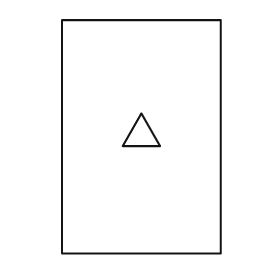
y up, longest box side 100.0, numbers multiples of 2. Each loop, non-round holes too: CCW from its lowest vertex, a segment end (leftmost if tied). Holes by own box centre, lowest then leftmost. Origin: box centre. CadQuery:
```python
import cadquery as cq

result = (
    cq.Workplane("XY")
    .moveTo(-34.0, -50.0)
    .lineTo(34.0, -50.0)
    .lineTo(34.0, 50.0)
    .lineTo(-34.0, 50.0)
    .close()
    .moveTo(-8.0, -4.0)
    .lineTo(8.0, -4.0)
    .lineTo(0.0, 10.0)
    .close()
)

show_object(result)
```